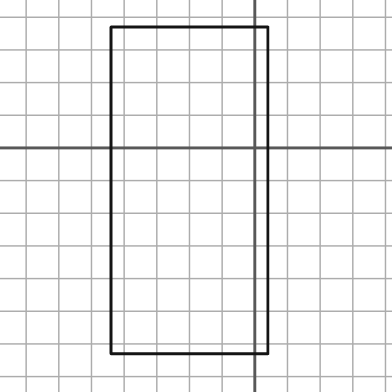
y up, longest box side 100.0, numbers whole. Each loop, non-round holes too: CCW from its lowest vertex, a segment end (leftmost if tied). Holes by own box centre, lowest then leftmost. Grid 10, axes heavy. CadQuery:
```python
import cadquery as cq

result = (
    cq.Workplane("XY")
    .moveTo(-44.0, -63.0)
    .lineTo(4.0, -63.0)
    .lineTo(4.0, 37.0)
    .lineTo(-44.0, 37.0)
    .close()
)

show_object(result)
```